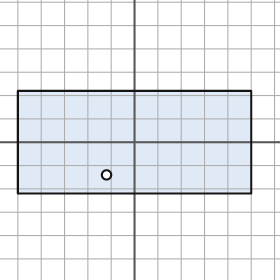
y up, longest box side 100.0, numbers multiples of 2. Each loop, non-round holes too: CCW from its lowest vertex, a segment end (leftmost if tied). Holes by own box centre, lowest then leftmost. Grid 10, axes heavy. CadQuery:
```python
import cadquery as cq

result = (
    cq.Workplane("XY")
    .moveTo(-50.0, -22.0)
    .lineTo(50.0, -22.0)
    .lineTo(50.0, 22.0)
    .lineTo(-50.0, 22.0)
    .close()
    .moveTo(-12.0, -14.0)
    .circle(2.0)
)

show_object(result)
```